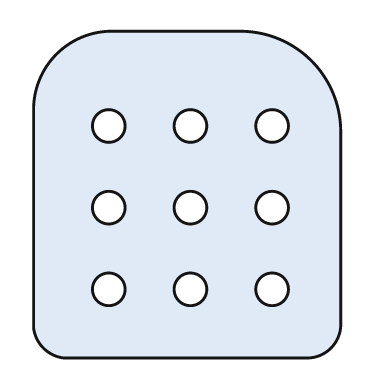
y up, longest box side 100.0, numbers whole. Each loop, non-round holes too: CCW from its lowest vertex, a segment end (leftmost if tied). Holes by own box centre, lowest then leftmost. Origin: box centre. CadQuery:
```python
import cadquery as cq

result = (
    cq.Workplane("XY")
    .moveTo(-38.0, -50.0)
    .lineTo(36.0, -50.0)
    .threePointArc((44.0, -47.0), (47.0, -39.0))
    .lineTo(47.0, 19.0)
    .threePointArc((38.0, 41.0), (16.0, 50.0))
    .lineTo(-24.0, 50.0)
    .threePointArc((-40.0, 43.0), (-47.0, 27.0))
    .lineTo(-47.0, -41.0)
    .threePointArc((-44.0, -47.0), (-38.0, -50.0))
    .close()
    .moveTo(-24.0, -29.0)
    .circle(5.0)
    .moveTo(1.0, -29.0)
    .circle(5.0)
    .moveTo(26.0, -29.0)
    .circle(5.0)
    .moveTo(-24.0, -4.0)
    .circle(5.0)
    .moveTo(1.0, -4.0)
    .circle(5.0)
    .moveTo(26.0, -4.0)
    .circle(5.0)
    .moveTo(-24.0, 21.0)
    .circle(5.0)
    .moveTo(1.0, 21.0)
    .circle(5.0)
    .moveTo(26.0, 21.0)
    .circle(5.0)
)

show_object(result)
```